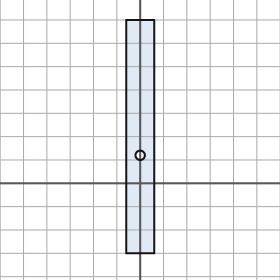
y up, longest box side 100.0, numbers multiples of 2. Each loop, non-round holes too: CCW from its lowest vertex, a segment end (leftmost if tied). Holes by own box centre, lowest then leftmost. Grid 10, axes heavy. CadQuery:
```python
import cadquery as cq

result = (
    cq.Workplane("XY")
    .moveTo(-6.0, -30.0)
    .lineTo(6.0, -30.0)
    .lineTo(6.0, 70.0)
    .lineTo(-6.0, 70.0)
    .close()
    .moveTo(0.0, 12.0)
    .circle(2.0)
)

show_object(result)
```